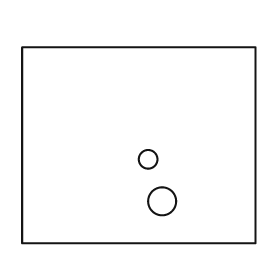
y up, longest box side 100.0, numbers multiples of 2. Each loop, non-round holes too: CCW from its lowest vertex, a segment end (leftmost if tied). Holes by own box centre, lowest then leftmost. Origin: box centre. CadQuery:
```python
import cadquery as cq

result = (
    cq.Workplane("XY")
    .moveTo(-50.0, -42.0)
    .lineTo(50.0, -42.0)
    .lineTo(50.0, 42.0)
    .lineTo(-50.0, 42.0)
    .close()
    .moveTo(10.0, -24.0)
    .circle(6.0)
    .moveTo(4.0, -6.0)
    .circle(4.0)
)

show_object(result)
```